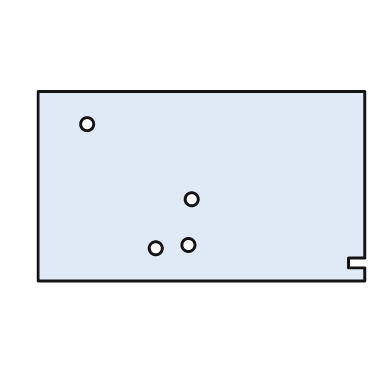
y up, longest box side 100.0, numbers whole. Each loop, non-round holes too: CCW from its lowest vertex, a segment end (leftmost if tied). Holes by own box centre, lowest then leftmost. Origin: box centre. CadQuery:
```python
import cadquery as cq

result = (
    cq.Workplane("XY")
    .moveTo(-50.0, -29.0)
    .lineTo(50.0, -29.0)
    .lineTo(50.0, -25.0)
    .lineTo(45.0, -25.0)
    .lineTo(45.0, -22.0)
    .lineTo(50.0, -22.0)
    .lineTo(50.0, 29.0)
    .lineTo(-50.0, 29.0)
    .close()
    .moveTo(-14.0, -19.0)
    .circle(2.0)
    .moveTo(-4.0, -18.0)
    .circle(2.0)
    .moveTo(-3.0, -4.0)
    .circle(2.0)
    .moveTo(-35.0, 19.0)
    .circle(2.0)
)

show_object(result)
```